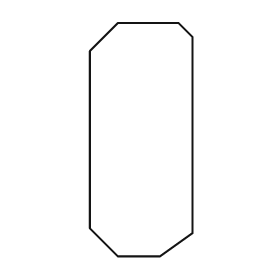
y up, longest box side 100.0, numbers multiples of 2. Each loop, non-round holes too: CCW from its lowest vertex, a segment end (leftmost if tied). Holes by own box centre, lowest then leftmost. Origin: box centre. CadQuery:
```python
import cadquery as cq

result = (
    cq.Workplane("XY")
    .moveTo(-10.0, -50.0)
    .lineTo(8.0, -50.0)
    .lineTo(22.0, -40.0)
    .lineTo(22.0, 44.0)
    .lineTo(16.0, 50.0)
    .lineTo(-10.0, 50.0)
    .lineTo(-22.0, 38.0)
    .lineTo(-22.0, -38.0)
    .close()
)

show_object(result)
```